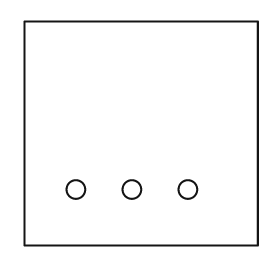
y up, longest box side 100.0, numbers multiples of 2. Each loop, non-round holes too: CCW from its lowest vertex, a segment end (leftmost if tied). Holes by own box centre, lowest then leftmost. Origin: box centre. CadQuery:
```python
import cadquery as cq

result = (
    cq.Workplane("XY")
    .moveTo(-50.0, -48.0)
    .lineTo(50.0, -48.0)
    .lineTo(50.0, 48.0)
    .lineTo(-50.0, 48.0)
    .close()
    .moveTo(-28.0, -24.0)
    .circle(4.0)
    .moveTo(-4.0, -24.0)
    .circle(4.0)
    .moveTo(20.0, -24.0)
    .circle(4.0)
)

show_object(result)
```